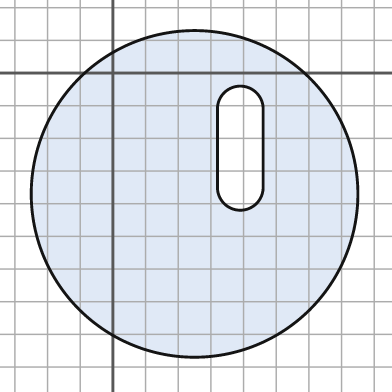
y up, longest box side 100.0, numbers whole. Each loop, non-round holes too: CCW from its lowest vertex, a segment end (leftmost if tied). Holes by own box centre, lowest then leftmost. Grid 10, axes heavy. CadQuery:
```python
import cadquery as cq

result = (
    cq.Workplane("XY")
    .moveTo(25.0, -37.0)
    .circle(50.0)
    .moveTo(32.0, -35.0)
    .threePointArc((39.0, -42.0), (46.0, -35.0))
    .lineTo(46.0, -11.0)
    .threePointArc((39.0, -4.0), (32.0, -11.0))
    .close()
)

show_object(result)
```